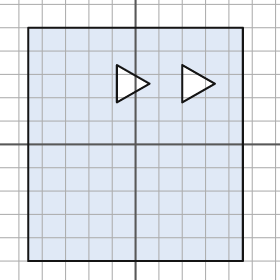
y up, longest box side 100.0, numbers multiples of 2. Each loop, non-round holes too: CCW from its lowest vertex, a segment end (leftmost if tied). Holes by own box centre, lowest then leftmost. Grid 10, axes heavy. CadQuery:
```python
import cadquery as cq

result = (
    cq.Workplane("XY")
    .moveTo(-46.0, -50.0)
    .lineTo(46.0, -50.0)
    .lineTo(46.0, 50.0)
    .lineTo(-46.0, 50.0)
    .close()
    .moveTo(-8.0, 18.0)
    .lineTo(6.0, 26.0)
    .lineTo(-8.0, 34.0)
    .close()
    .moveTo(20.0, 18.0)
    .lineTo(34.0, 26.0)
    .lineTo(20.0, 34.0)
    .close()
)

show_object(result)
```